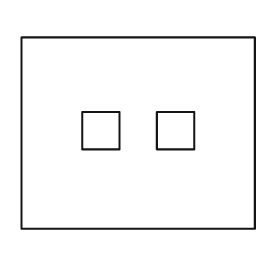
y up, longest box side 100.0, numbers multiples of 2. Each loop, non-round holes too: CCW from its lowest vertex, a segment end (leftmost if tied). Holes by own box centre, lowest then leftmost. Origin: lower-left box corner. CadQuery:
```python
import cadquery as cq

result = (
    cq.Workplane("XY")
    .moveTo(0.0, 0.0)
    .lineTo(100.0, 0.0)
    .lineTo(100.0, 82.0)
    .lineTo(0.0, 82.0)
    .close()
    .moveTo(26.0, 34.0)
    .lineTo(42.0, 34.0)
    .lineTo(42.0, 50.0)
    .lineTo(26.0, 50.0)
    .close()
    .moveTo(58.0, 34.0)
    .lineTo(74.0, 34.0)
    .lineTo(74.0, 50.0)
    .lineTo(58.0, 50.0)
    .close()
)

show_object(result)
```